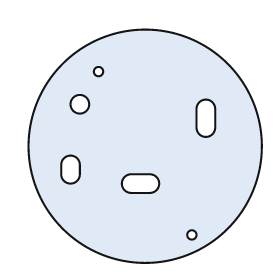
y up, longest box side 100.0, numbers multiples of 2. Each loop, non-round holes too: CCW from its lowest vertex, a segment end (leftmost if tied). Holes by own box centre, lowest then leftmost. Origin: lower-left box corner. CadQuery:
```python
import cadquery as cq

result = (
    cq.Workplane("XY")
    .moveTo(50.0, 50.0)
    .circle(50.0)
    .moveTo(70.0, 12.0)
    .circle(2.0)
    .moveTo(44.0, 30.0)
    .lineTo(52.0, 30.0)
    .threePointArc((56.0, 34.0), (52.0, 38.0))
    .lineTo(44.0, 38.0)
    .threePointArc((40.0, 34.0), (44.0, 30.0))
    .close()
    .moveTo(14.0, 38.0)
    .threePointArc((18.0, 34.0), (22.0, 38.0))
    .lineTo(22.0, 42.0)
    .threePointArc((18.0, 46.0), (14.0, 42.0))
    .close()
    .moveTo(72.0, 58.0)
    .threePointArc((76.0, 54.0), (80.0, 58.0))
    .lineTo(80.0, 66.0)
    .threePointArc((76.0, 70.0), (72.0, 66.0))
    .close()
    .moveTo(22.0, 68.0)
    .circle(4.0)
    .moveTo(30.0, 82.0)
    .circle(2.0)
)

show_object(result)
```